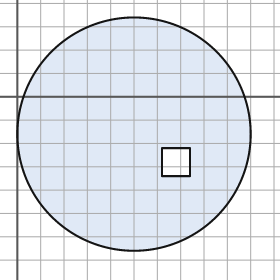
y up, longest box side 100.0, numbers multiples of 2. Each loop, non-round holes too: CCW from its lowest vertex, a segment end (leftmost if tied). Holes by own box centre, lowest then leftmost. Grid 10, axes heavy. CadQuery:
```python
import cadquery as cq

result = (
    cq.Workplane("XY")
    .moveTo(50.0, -16.0)
    .circle(50.0)
    .moveTo(62.0, -34.0)
    .lineTo(74.0, -34.0)
    .lineTo(74.0, -22.0)
    .lineTo(62.0, -22.0)
    .close()
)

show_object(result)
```